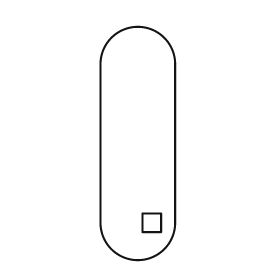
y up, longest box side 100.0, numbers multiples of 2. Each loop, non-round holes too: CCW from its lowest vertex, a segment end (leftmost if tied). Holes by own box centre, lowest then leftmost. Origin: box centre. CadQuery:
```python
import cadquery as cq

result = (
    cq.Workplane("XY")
    .moveTo(-16.0, -34.0)
    .threePointArc((0.0, -50.0), (16.0, -34.0))
    .lineTo(16.0, 34.0)
    .threePointArc((0.0, 50.0), (-16.0, 34.0))
    .close()
    .moveTo(2.0, -38.0)
    .lineTo(10.0, -38.0)
    .lineTo(10.0, -30.0)
    .lineTo(2.0, -30.0)
    .close()
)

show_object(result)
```